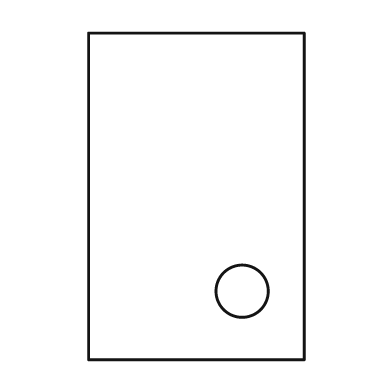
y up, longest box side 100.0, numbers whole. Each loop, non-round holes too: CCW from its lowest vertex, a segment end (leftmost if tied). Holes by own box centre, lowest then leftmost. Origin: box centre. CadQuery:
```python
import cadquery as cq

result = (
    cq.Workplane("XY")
    .moveTo(-33.0, -50.0)
    .lineTo(33.0, -50.0)
    .lineTo(33.0, 50.0)
    .lineTo(-33.0, 50.0)
    .close()
    .moveTo(14.0, -29.0)
    .circle(8.0)
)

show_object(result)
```